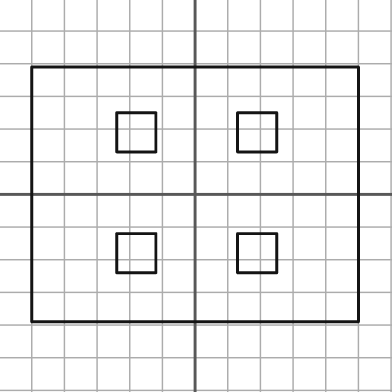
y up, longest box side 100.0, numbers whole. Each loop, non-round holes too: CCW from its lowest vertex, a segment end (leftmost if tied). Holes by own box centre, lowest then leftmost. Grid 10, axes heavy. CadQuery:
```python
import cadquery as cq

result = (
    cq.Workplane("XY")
    .moveTo(-50.0, -39.0)
    .lineTo(50.0, -39.0)
    .lineTo(50.0, 39.0)
    .lineTo(-50.0, 39.0)
    .close()
    .moveTo(-24.0, -24.0)
    .lineTo(-12.0, -24.0)
    .lineTo(-12.0, -12.0)
    .lineTo(-24.0, -12.0)
    .close()
    .moveTo(13.0, -24.0)
    .lineTo(25.0, -24.0)
    .lineTo(25.0, -12.0)
    .lineTo(13.0, -12.0)
    .close()
    .moveTo(-24.0, 13.0)
    .lineTo(-12.0, 13.0)
    .lineTo(-12.0, 25.0)
    .lineTo(-24.0, 25.0)
    .close()
    .moveTo(13.0, 13.0)
    .lineTo(25.0, 13.0)
    .lineTo(25.0, 25.0)
    .lineTo(13.0, 25.0)
    .close()
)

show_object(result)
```